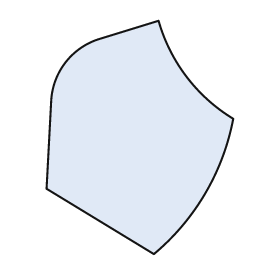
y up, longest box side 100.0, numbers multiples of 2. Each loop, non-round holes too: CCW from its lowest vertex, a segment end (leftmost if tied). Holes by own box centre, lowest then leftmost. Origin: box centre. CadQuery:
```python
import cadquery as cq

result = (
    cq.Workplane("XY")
    .moveTo(6.0, -50.0)
    .threePointArc((28.0, -24.0), (40.0, 8.0))
    .threePointArc((20.0, 26.0), (8.0, 50.0))
    .lineTo(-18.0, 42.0)
    .threePointArc((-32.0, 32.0), (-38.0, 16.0))
    .lineTo(-40.0, -22.0)
    .close()
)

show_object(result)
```